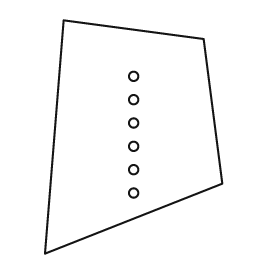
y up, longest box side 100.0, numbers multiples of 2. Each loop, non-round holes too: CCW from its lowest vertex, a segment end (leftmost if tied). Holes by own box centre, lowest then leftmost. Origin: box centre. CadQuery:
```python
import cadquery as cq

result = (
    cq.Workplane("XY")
    .moveTo(-38.0, -50.0)
    .lineTo(38.0, -20.0)
    .lineTo(30.0, 42.0)
    .lineTo(-30.0, 50.0)
    .close()
    .moveTo(0.0, -24.0)
    .circle(2.0)
    .moveTo(0.0, -14.0)
    .circle(2.0)
    .moveTo(0.0, -4.0)
    .circle(2.0)
    .moveTo(0.0, 6.0)
    .circle(2.0)
    .moveTo(0.0, 16.0)
    .circle(2.0)
    .moveTo(0.0, 26.0)
    .circle(2.0)
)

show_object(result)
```